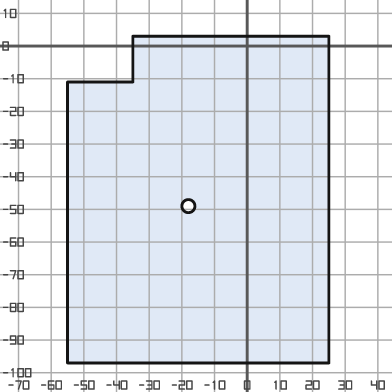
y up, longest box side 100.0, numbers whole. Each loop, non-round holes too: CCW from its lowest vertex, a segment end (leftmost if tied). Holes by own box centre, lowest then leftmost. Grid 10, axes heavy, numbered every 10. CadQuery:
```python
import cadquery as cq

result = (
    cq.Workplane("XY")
    .moveTo(-55.0, -97.0)
    .lineTo(25.0, -97.0)
    .lineTo(25.0, 3.0)
    .lineTo(-35.0, 3.0)
    .lineTo(-35.0, -11.0)
    .lineTo(-55.0, -11.0)
    .close()
    .moveTo(-18.0, -49.0)
    .circle(2.0)
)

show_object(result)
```